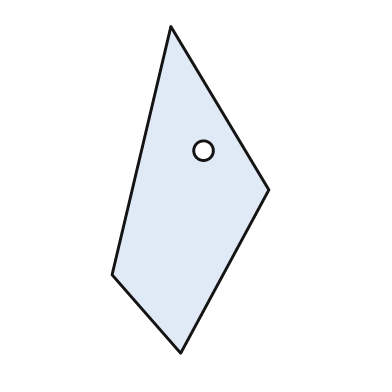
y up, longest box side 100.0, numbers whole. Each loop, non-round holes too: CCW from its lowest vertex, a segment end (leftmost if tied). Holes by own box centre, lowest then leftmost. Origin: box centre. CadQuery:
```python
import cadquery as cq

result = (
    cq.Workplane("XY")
    .moveTo(-3.0, -50.0)
    .lineTo(24.0, 0.0)
    .lineTo(-6.0, 50.0)
    .lineTo(-24.0, -26.0)
    .close()
    .moveTo(4.0, 12.0)
    .circle(3.0)
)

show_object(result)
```